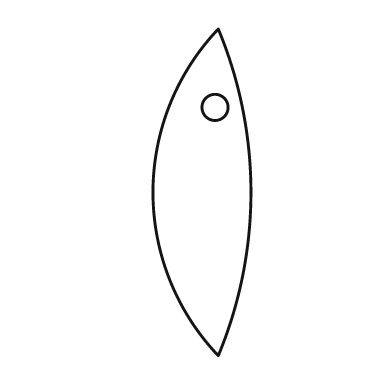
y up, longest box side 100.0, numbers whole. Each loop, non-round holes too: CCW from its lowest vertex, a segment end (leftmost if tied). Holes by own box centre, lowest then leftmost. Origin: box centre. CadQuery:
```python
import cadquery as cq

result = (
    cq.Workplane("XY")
    .moveTo(5.0, -50.0)
    .threePointArc((15.0, 0.0), (5.0, 50.0))
    .threePointArc((-15.0, 0.0), (5.0, -50.0))
    .close()
    .moveTo(4.0, 26.0)
    .circle(4.0)
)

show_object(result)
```